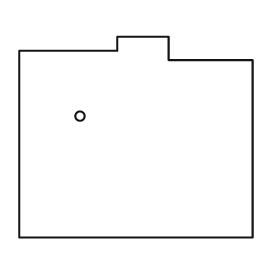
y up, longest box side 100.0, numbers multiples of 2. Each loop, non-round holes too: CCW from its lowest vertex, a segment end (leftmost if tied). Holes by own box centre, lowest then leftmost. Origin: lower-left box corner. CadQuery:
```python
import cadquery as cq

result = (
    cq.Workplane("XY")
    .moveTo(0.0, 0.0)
    .lineTo(100.0, 0.0)
    .lineTo(100.0, 76.0)
    .lineTo(64.0, 76.0)
    .lineTo(64.0, 86.0)
    .lineTo(42.0, 86.0)
    .lineTo(42.0, 80.0)
    .lineTo(0.0, 80.0)
    .close()
    .moveTo(26.0, 52.0)
    .circle(2.0)
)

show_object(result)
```